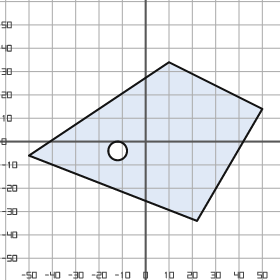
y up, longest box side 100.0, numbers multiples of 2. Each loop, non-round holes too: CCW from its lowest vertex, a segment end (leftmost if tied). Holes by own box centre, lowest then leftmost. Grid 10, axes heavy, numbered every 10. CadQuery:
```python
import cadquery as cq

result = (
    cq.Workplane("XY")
    .moveTo(22.0, -34.0)
    .lineTo(50.0, 14.0)
    .lineTo(10.0, 34.0)
    .lineTo(-50.0, -6.0)
    .close()
    .moveTo(-12.0, -4.0)
    .circle(4.0)
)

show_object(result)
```